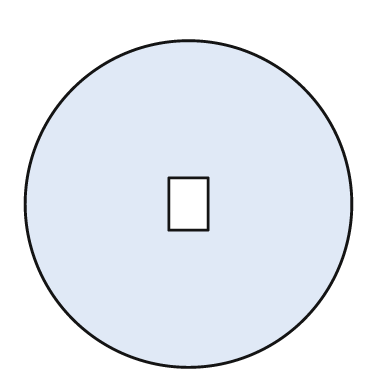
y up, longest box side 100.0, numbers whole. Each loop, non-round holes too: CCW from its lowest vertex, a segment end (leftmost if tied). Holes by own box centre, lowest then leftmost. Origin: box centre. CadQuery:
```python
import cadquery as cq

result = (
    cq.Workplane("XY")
    .moveTo(0.0, 0.0)
    .circle(50.0)
    .moveTo(-6.0, -8.0)
    .lineTo(6.0, -8.0)
    .lineTo(6.0, 8.0)
    .lineTo(-6.0, 8.0)
    .close()
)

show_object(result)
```